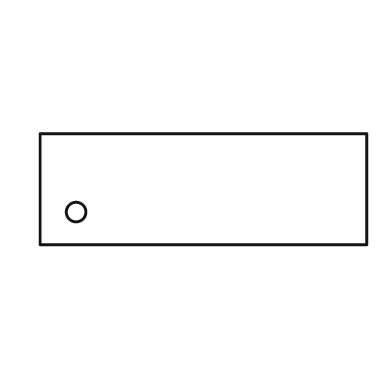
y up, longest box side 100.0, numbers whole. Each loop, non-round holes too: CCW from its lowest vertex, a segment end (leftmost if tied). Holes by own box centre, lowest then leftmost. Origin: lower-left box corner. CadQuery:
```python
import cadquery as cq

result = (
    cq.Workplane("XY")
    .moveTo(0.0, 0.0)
    .lineTo(100.0, 0.0)
    .lineTo(100.0, 34.0)
    .lineTo(0.0, 34.0)
    .close()
    .moveTo(11.0, 10.0)
    .circle(3.0)
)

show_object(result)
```